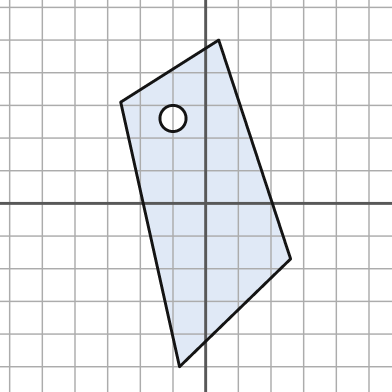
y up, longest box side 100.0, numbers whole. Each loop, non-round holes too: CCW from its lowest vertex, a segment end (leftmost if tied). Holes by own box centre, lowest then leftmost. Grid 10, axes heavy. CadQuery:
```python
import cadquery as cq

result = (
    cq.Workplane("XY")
    .moveTo(-8.0, -50.0)
    .lineTo(26.0, -17.0)
    .lineTo(4.0, 50.0)
    .lineTo(-26.0, 31.0)
    .close()
    .moveTo(-10.0, 26.0)
    .circle(4.0)
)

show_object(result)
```